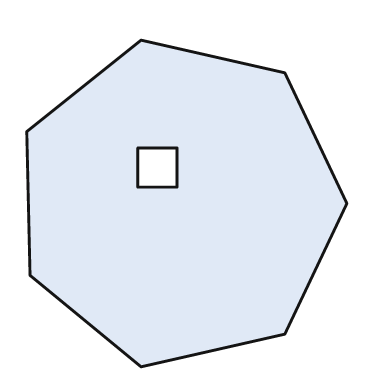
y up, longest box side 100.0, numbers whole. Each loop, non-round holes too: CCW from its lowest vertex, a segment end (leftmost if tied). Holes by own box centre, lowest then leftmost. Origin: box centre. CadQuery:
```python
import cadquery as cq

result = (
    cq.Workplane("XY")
    .moveTo(-14.0, -50.0)
    .lineTo(30.0, -40.0)
    .lineTo(49.0, 0.0)
    .lineTo(30.0, 40.0)
    .lineTo(-14.0, 50.0)
    .lineTo(-49.0, 22.0)
    .lineTo(-48.0, -22.0)
    .close()
    .moveTo(-15.0, 5.0)
    .lineTo(-3.0, 5.0)
    .lineTo(-3.0, 17.0)
    .lineTo(-15.0, 17.0)
    .close()
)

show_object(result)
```